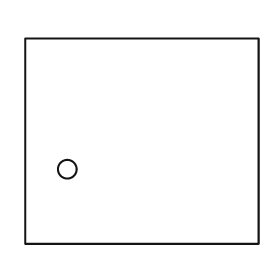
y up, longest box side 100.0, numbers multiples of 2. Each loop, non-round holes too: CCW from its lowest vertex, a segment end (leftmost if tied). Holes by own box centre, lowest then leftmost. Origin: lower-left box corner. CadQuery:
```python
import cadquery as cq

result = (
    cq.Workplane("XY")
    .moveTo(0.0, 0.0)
    .lineTo(100.0, 0.0)
    .lineTo(100.0, 88.0)
    .lineTo(0.0, 88.0)
    .close()
    .moveTo(18.0, 32.0)
    .circle(4.0)
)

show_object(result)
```